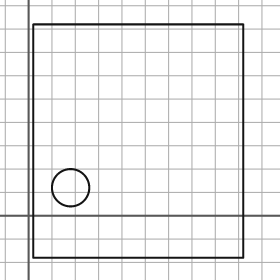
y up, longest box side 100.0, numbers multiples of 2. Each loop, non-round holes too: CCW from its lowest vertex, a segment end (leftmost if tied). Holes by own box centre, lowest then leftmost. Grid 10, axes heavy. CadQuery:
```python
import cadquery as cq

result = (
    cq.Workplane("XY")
    .moveTo(2.0, -18.0)
    .lineTo(92.0, -18.0)
    .lineTo(92.0, 82.0)
    .lineTo(2.0, 82.0)
    .close()
    .moveTo(18.0, 12.0)
    .circle(8.0)
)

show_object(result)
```